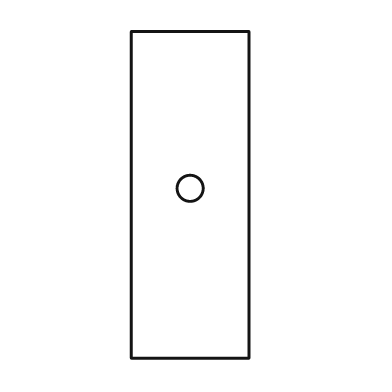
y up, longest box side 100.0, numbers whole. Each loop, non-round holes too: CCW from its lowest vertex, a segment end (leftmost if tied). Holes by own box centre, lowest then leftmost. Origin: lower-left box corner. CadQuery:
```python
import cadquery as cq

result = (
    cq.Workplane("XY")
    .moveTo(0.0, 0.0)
    .lineTo(36.0, 0.0)
    .lineTo(36.0, 100.0)
    .lineTo(0.0, 100.0)
    .close()
    .moveTo(18.0, 52.0)
    .circle(4.0)
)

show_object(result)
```